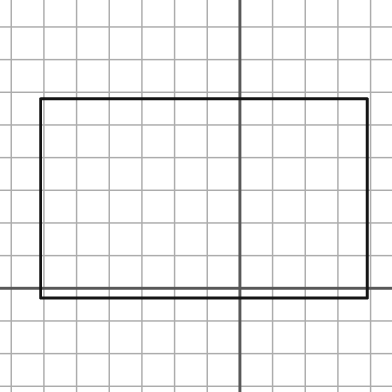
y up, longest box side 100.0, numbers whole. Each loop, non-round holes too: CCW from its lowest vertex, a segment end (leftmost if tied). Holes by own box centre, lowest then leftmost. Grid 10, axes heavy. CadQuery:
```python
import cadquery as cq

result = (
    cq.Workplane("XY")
    .moveTo(-61.0, -3.0)
    .lineTo(39.0, -3.0)
    .lineTo(39.0, 58.0)
    .lineTo(-61.0, 58.0)
    .close()
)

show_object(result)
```